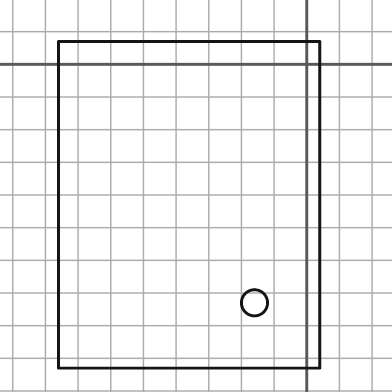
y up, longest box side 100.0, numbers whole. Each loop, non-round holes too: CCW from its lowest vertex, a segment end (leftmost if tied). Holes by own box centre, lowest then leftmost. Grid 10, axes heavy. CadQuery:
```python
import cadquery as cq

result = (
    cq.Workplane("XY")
    .moveTo(-76.0, -93.0)
    .lineTo(4.0, -93.0)
    .lineTo(4.0, 7.0)
    .lineTo(-76.0, 7.0)
    .close()
    .moveTo(-16.0, -73.0)
    .circle(4.0)
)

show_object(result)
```